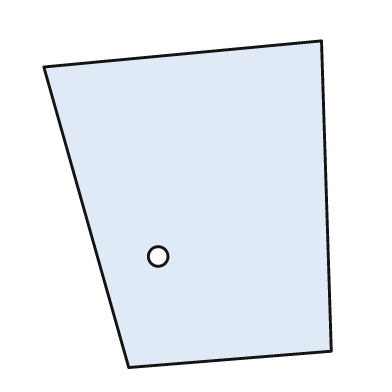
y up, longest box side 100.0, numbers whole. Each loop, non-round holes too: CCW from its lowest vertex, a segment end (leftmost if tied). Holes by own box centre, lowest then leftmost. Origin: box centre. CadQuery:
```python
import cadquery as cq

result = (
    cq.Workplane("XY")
    .moveTo(-18.0, -50.0)
    .lineTo(44.0, -45.0)
    .lineTo(41.0, 50.0)
    .lineTo(-44.0, 42.0)
    .close()
    .moveTo(-9.0, -16.0)
    .circle(3.0)
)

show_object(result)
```